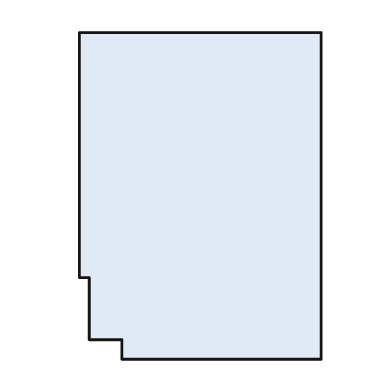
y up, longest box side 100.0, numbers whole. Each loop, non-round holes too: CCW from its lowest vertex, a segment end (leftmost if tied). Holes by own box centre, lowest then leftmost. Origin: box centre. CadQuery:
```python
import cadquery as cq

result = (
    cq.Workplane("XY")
    .moveTo(-24.0, -50.0)
    .lineTo(37.0, -50.0)
    .lineTo(37.0, 50.0)
    .lineTo(-37.0, 50.0)
    .lineTo(-37.0, -25.0)
    .lineTo(-34.0, -25.0)
    .lineTo(-34.0, -44.0)
    .lineTo(-24.0, -44.0)
    .close()
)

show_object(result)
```